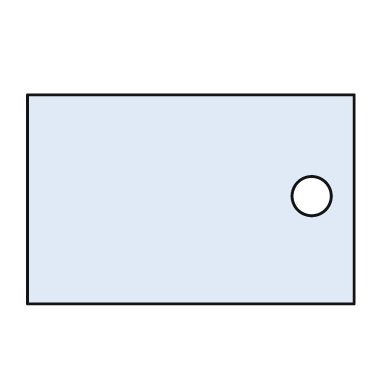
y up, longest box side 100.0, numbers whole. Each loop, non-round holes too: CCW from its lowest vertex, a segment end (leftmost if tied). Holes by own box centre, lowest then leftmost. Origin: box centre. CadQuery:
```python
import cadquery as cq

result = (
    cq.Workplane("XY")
    .moveTo(-50.0, -32.0)
    .lineTo(50.0, -32.0)
    .lineTo(50.0, 32.0)
    .lineTo(-50.0, 32.0)
    .close()
    .moveTo(37.0, 1.0)
    .circle(6.0)
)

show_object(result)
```